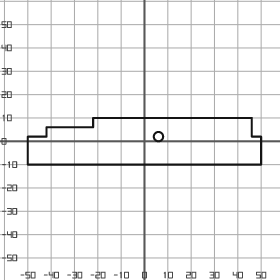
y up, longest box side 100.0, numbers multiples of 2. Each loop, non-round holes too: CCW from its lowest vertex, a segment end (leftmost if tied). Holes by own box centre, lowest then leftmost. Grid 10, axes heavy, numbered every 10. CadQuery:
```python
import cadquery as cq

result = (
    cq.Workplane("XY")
    .moveTo(-50.0, -10.0)
    .lineTo(50.0, -10.0)
    .lineTo(50.0, 2.0)
    .lineTo(46.0, 2.0)
    .lineTo(46.0, 10.0)
    .lineTo(-22.0, 10.0)
    .lineTo(-22.0, 6.0)
    .lineTo(-42.0, 6.0)
    .lineTo(-42.0, 2.0)
    .lineTo(-50.0, 2.0)
    .close()
    .moveTo(6.0, 2.0)
    .circle(2.0)
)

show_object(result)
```